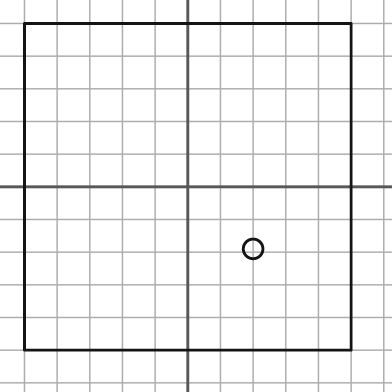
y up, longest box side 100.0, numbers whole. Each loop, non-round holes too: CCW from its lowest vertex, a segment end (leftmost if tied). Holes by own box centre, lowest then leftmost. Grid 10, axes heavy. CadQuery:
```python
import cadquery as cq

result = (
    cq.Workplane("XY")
    .moveTo(-50.0, -50.0)
    .lineTo(50.0, -50.0)
    .lineTo(50.0, 50.0)
    .lineTo(-50.0, 50.0)
    .close()
    .moveTo(20.0, -19.0)
    .circle(3.0)
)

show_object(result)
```